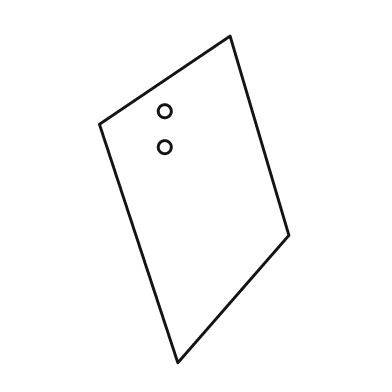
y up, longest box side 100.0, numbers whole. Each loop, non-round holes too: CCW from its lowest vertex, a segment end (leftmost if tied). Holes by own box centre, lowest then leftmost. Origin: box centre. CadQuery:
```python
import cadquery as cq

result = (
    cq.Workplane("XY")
    .moveTo(-5.0, -50.0)
    .lineTo(29.0, -11.0)
    .lineTo(11.0, 50.0)
    .lineTo(-29.0, 23.0)
    .close()
    .moveTo(-9.0, 16.0)
    .circle(2.0)
    .moveTo(-9.0, 27.0)
    .circle(2.0)
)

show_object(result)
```